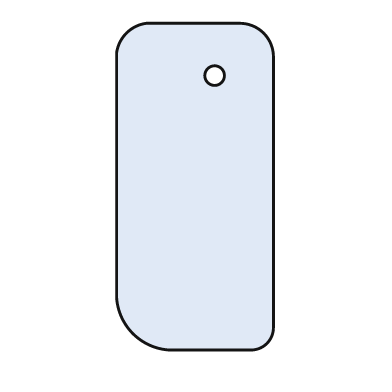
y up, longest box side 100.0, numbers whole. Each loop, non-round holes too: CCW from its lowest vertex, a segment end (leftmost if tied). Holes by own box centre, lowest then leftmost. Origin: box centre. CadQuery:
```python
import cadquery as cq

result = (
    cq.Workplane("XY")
    .moveTo(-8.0, -50.0)
    .lineTo(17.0, -50.0)
    .threePointArc((22.0, -48.0), (24.0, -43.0))
    .lineTo(24.0, 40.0)
    .threePointArc((21.0, 47.0), (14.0, 50.0))
    .lineTo(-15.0, 50.0)
    .threePointArc((-21.0, 47.0), (-24.0, 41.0))
    .lineTo(-24.0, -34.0)
    .threePointArc((-19.0, -45.0), (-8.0, -50.0))
    .close()
    .moveTo(6.0, 34.0)
    .circle(3.0)
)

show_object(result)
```